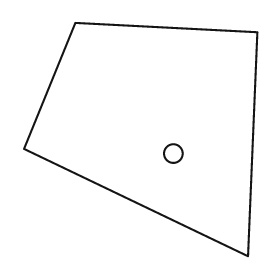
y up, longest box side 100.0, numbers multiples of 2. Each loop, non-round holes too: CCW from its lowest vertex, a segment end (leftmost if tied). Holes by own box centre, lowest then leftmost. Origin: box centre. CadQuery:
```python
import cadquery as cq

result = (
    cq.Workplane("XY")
    .moveTo(46.0, -50.0)
    .lineTo(50.0, 46.0)
    .lineTo(-28.0, 50.0)
    .lineTo(-50.0, -4.0)
    .close()
    .moveTo(14.0, -6.0)
    .circle(4.0)
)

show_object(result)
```